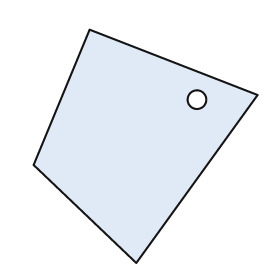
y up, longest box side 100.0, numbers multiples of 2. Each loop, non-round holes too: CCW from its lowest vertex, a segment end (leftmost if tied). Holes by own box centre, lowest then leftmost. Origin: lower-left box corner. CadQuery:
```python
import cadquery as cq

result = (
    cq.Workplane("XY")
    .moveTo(44.0, 0.0)
    .lineTo(96.0, 72.0)
    .lineTo(24.0, 100.0)
    .lineTo(0.0, 42.0)
    .close()
    .moveTo(70.0, 70.0)
    .circle(4.0)
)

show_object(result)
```